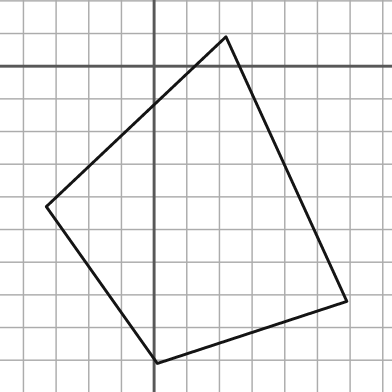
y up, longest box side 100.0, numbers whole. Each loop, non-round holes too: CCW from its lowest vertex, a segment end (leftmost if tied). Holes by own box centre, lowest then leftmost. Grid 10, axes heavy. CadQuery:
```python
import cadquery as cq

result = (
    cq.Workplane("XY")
    .moveTo(1.0, -91.0)
    .lineTo(59.0, -72.0)
    .lineTo(22.0, 9.0)
    .lineTo(-33.0, -43.0)
    .close()
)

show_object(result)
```